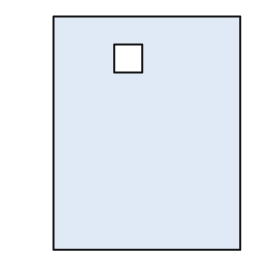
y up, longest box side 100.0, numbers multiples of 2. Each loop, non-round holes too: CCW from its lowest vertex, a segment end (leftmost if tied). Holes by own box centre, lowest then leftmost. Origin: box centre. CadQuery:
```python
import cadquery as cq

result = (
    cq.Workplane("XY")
    .moveTo(-40.0, -50.0)
    .lineTo(40.0, -50.0)
    .lineTo(40.0, 50.0)
    .lineTo(-40.0, 50.0)
    .close()
    .moveTo(-14.0, 26.0)
    .lineTo(-2.0, 26.0)
    .lineTo(-2.0, 38.0)
    .lineTo(-14.0, 38.0)
    .close()
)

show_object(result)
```